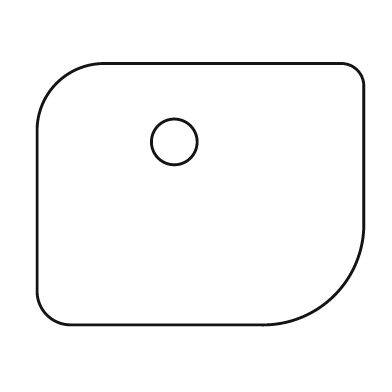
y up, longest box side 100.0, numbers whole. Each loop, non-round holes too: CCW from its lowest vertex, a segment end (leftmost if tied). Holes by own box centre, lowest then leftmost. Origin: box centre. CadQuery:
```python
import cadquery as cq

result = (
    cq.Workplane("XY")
    .moveTo(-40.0, -40.0)
    .lineTo(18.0, -40.0)
    .threePointArc((41.0, -31.0), (50.0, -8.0))
    .lineTo(50.0, 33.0)
    .threePointArc((48.0, 38.0), (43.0, 40.0))
    .lineTo(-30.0, 40.0)
    .threePointArc((-44.0, 34.0), (-50.0, 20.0))
    .lineTo(-50.0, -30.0)
    .threePointArc((-47.0, -37.0), (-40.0, -40.0))
    .close()
    .moveTo(-8.0, 16.0)
    .circle(7.0)
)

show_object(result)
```